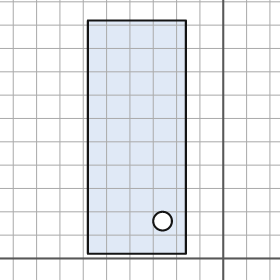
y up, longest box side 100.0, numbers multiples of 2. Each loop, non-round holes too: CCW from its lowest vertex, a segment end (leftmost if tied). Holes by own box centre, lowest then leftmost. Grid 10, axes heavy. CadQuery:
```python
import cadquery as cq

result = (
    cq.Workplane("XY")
    .moveTo(-58.0, 2.0)
    .lineTo(-16.0, 2.0)
    .lineTo(-16.0, 102.0)
    .lineTo(-58.0, 102.0)
    .close()
    .moveTo(-26.0, 16.0)
    .circle(4.0)
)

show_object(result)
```